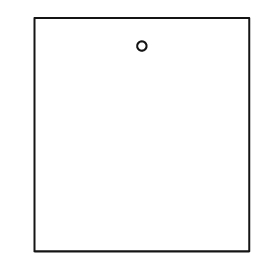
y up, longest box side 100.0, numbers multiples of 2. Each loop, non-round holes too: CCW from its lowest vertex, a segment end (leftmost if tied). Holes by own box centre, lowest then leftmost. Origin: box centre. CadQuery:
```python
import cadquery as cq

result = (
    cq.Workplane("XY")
    .moveTo(-46.0, -50.0)
    .lineTo(46.0, -50.0)
    .lineTo(46.0, 50.0)
    .lineTo(-46.0, 50.0)
    .close()
    .moveTo(0.0, 38.0)
    .circle(2.0)
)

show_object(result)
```